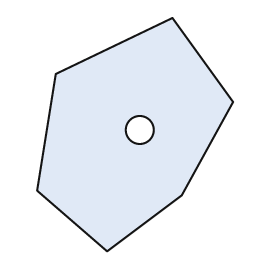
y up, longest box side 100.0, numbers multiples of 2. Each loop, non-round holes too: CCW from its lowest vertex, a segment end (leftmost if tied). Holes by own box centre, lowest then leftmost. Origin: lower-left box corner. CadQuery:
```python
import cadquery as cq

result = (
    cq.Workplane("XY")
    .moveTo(30.0, 0.0)
    .lineTo(62.0, 24.0)
    .lineTo(84.0, 64.0)
    .lineTo(58.0, 100.0)
    .lineTo(8.0, 76.0)
    .lineTo(0.0, 26.0)
    .close()
    .moveTo(44.0, 52.0)
    .circle(6.0)
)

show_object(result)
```